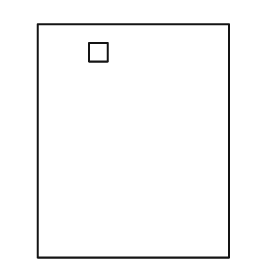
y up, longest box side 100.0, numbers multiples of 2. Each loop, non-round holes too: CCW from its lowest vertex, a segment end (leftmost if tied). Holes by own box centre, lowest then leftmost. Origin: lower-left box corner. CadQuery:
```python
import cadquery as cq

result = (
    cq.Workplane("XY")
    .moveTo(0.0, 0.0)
    .lineTo(82.0, 0.0)
    .lineTo(82.0, 100.0)
    .lineTo(0.0, 100.0)
    .close()
    .moveTo(22.0, 84.0)
    .lineTo(30.0, 84.0)
    .lineTo(30.0, 92.0)
    .lineTo(22.0, 92.0)
    .close()
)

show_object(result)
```